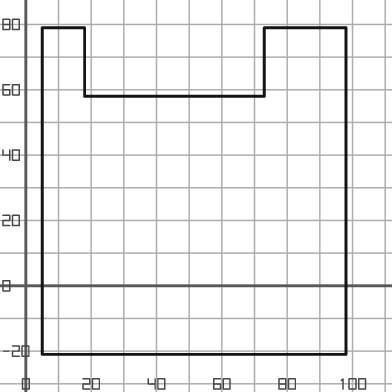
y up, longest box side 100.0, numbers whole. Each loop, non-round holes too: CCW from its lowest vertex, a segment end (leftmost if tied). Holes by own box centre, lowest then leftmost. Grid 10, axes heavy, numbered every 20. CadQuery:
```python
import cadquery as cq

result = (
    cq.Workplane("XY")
    .moveTo(5.0, -21.0)
    .lineTo(98.0, -21.0)
    .lineTo(98.0, 79.0)
    .lineTo(73.0, 79.0)
    .lineTo(73.0, 58.0)
    .lineTo(18.0, 58.0)
    .lineTo(18.0, 79.0)
    .lineTo(5.0, 79.0)
    .close()
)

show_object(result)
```